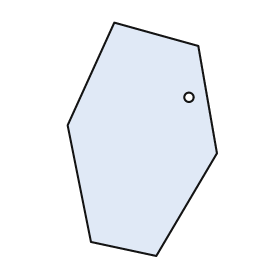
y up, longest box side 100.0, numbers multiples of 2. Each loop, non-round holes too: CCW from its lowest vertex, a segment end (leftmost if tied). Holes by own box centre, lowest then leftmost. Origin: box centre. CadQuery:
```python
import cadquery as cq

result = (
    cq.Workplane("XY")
    .moveTo(6.0, -50.0)
    .lineTo(32.0, -6.0)
    .lineTo(24.0, 40.0)
    .lineTo(-12.0, 50.0)
    .lineTo(-32.0, 6.0)
    .lineTo(-22.0, -44.0)
    .close()
    .moveTo(20.0, 18.0)
    .circle(2.0)
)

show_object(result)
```